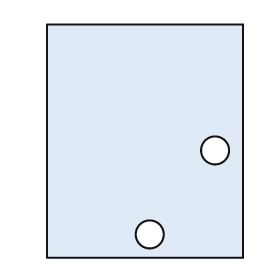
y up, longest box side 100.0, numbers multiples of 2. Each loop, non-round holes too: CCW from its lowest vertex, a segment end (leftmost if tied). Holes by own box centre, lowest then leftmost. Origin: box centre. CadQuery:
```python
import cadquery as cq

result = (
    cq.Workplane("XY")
    .moveTo(-42.0, -50.0)
    .lineTo(42.0, -50.0)
    .lineTo(42.0, 50.0)
    .lineTo(-42.0, 50.0)
    .close()
    .moveTo(2.0, -40.0)
    .circle(6.0)
    .moveTo(30.0, -4.0)
    .circle(6.0)
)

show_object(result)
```